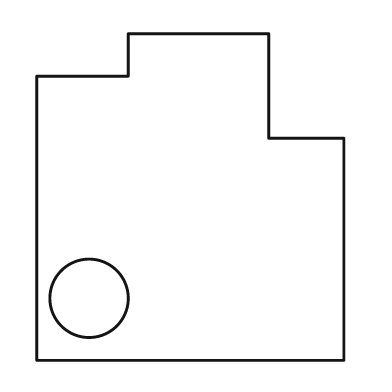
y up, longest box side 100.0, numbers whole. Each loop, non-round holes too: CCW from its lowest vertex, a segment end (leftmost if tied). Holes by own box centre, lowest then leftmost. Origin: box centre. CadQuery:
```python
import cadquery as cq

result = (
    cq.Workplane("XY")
    .moveTo(-47.0, -50.0)
    .lineTo(47.0, -50.0)
    .lineTo(47.0, 18.0)
    .lineTo(24.0, 18.0)
    .lineTo(24.0, 50.0)
    .lineTo(-19.0, 50.0)
    .lineTo(-19.0, 37.0)
    .lineTo(-47.0, 37.0)
    .close()
    .moveTo(-31.0, -31.0)
    .circle(12.0)
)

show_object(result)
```